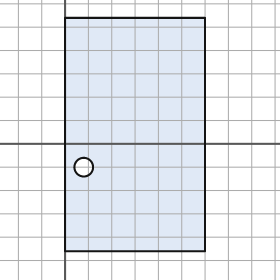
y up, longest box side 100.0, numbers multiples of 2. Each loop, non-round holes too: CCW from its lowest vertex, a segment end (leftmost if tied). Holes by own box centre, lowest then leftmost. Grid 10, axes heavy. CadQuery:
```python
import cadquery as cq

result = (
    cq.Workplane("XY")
    .moveTo(0.0, -46.0)
    .lineTo(60.0, -46.0)
    .lineTo(60.0, 54.0)
    .lineTo(0.0, 54.0)
    .close()
    .moveTo(8.0, -10.0)
    .circle(4.0)
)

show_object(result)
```